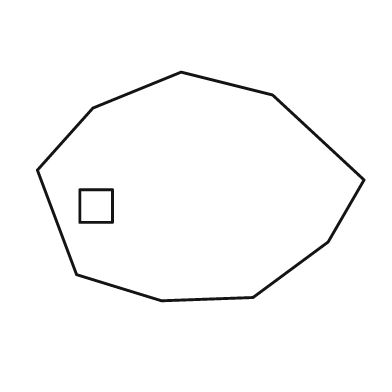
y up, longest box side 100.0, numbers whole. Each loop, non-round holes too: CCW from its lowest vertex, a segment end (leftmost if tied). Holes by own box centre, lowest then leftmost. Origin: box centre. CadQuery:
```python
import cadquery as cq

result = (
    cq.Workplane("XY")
    .moveTo(-12.0, -35.0)
    .lineTo(16.0, -34.0)
    .lineTo(39.0, -17.0)
    .lineTo(50.0, 2.0)
    .lineTo(22.0, 28.0)
    .lineTo(-6.0, 35.0)
    .lineTo(-33.0, 24.0)
    .lineTo(-50.0, 5.0)
    .lineTo(-38.0, -27.0)
    .close()
    .moveTo(-37.0, -11.0)
    .lineTo(-27.0, -11.0)
    .lineTo(-27.0, -1.0)
    .lineTo(-37.0, -1.0)
    .close()
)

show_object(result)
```